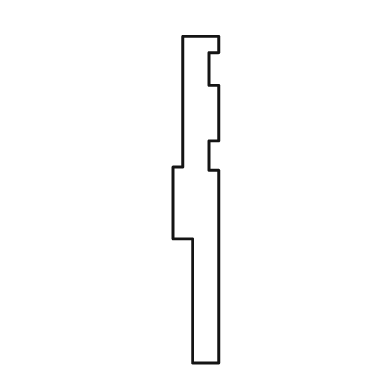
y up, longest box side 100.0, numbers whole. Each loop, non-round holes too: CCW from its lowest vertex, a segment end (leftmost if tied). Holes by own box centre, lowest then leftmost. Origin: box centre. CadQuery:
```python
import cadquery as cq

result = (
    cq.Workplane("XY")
    .moveTo(-1.0, -50.0)
    .lineTo(7.0, -50.0)
    .lineTo(7.0, 9.0)
    .lineTo(4.0, 9.0)
    .lineTo(4.0, 18.0)
    .lineTo(7.0, 18.0)
    .lineTo(7.0, 35.0)
    .lineTo(4.0, 35.0)
    .lineTo(4.0, 45.0)
    .lineTo(7.0, 45.0)
    .lineTo(7.0, 50.0)
    .lineTo(-4.0, 50.0)
    .lineTo(-4.0, 10.0)
    .lineTo(-7.0, 10.0)
    .lineTo(-7.0, -12.0)
    .lineTo(-1.0, -12.0)
    .close()
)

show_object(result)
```